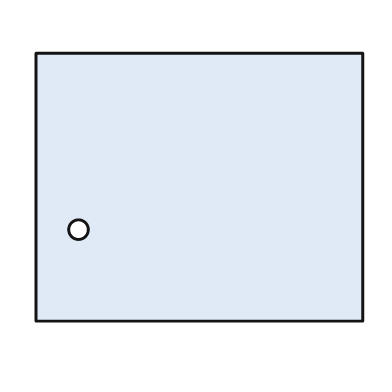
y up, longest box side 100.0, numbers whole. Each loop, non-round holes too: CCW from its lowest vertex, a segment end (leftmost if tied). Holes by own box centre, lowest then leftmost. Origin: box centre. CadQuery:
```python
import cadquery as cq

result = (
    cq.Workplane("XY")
    .moveTo(-50.0, -41.0)
    .lineTo(50.0, -41.0)
    .lineTo(50.0, 41.0)
    .lineTo(-50.0, 41.0)
    .close()
    .moveTo(-37.0, -13.0)
    .circle(3.0)
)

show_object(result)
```